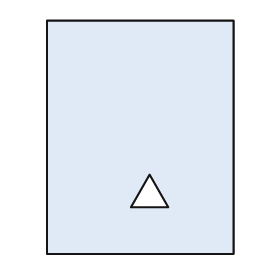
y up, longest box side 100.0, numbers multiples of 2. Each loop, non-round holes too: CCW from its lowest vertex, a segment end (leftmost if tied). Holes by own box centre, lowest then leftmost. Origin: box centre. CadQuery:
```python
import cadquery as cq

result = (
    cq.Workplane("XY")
    .moveTo(-40.0, -50.0)
    .lineTo(40.0, -50.0)
    .lineTo(40.0, 50.0)
    .lineTo(-40.0, 50.0)
    .close()
    .moveTo(-4.0, -30.0)
    .lineTo(12.0, -30.0)
    .lineTo(4.0, -16.0)
    .close()
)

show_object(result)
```